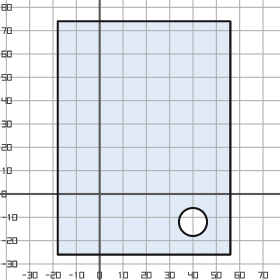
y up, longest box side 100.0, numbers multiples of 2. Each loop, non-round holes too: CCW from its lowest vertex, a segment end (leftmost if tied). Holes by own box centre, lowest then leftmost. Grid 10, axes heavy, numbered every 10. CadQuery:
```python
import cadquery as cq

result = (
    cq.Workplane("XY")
    .moveTo(-18.0, -26.0)
    .lineTo(56.0, -26.0)
    .lineTo(56.0, 74.0)
    .lineTo(-18.0, 74.0)
    .close()
    .moveTo(40.0, -12.0)
    .circle(6.0)
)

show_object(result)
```